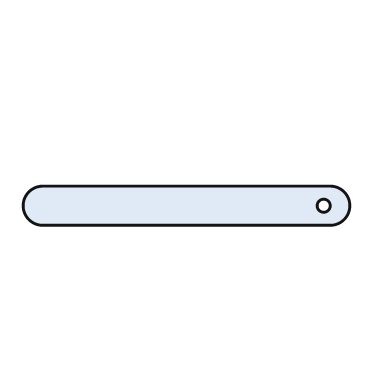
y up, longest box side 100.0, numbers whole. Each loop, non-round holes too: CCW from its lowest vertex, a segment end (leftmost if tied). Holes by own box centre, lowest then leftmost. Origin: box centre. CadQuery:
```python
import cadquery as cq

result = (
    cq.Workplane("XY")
    .moveTo(-44.0, -6.0)
    .lineTo(44.0, -6.0)
    .threePointArc((50.0, 0.0), (44.0, 6.0))
    .lineTo(-44.0, 6.0)
    .threePointArc((-50.0, 0.0), (-44.0, -6.0))
    .close()
    .moveTo(42.0, 0.0)
    .circle(2.0)
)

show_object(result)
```